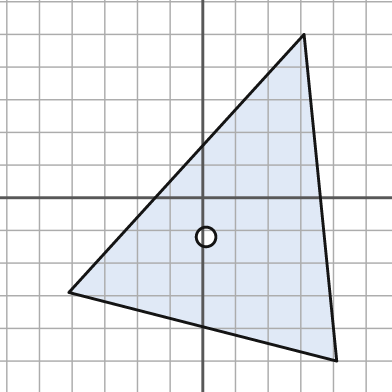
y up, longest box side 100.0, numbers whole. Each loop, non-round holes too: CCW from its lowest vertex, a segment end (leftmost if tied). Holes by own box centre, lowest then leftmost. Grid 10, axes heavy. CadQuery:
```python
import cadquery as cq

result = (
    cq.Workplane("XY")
    .moveTo(41.0, -50.0)
    .lineTo(31.0, 50.0)
    .lineTo(-41.0, -29.0)
    .close()
    .moveTo(1.0, -12.0)
    .circle(3.0)
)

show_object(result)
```